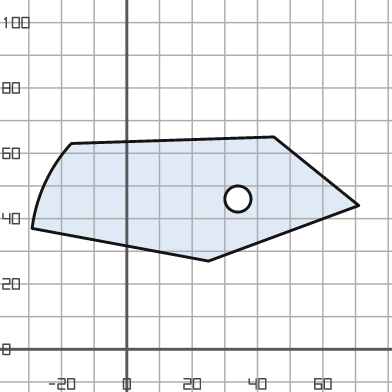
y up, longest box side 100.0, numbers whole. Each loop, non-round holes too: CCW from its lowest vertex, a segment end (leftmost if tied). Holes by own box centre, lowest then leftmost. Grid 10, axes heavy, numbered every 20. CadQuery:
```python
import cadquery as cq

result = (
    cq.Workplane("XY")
    .moveTo(25.0, 27.0)
    .lineTo(71.0, 44.0)
    .lineTo(45.0, 65.0)
    .lineTo(-17.0, 63.0)
    .threePointArc((-25.0, 51.0), (-29.0, 37.0))
    .close()
    .moveTo(34.0, 46.0)
    .circle(4.0)
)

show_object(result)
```